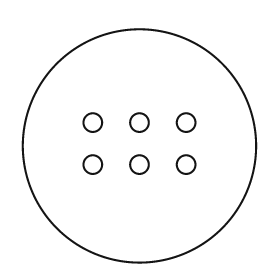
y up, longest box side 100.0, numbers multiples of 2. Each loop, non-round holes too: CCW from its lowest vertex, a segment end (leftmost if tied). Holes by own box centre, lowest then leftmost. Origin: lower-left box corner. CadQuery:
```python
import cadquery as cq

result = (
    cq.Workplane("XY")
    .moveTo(50.0, 50.0)
    .circle(50.0)
    .moveTo(30.0, 42.0)
    .circle(4.0)
    .moveTo(50.0, 42.0)
    .circle(4.0)
    .moveTo(70.0, 42.0)
    .circle(4.0)
    .moveTo(30.0, 60.0)
    .circle(4.0)
    .moveTo(50.0, 60.0)
    .circle(4.0)
    .moveTo(70.0, 60.0)
    .circle(4.0)
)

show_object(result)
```